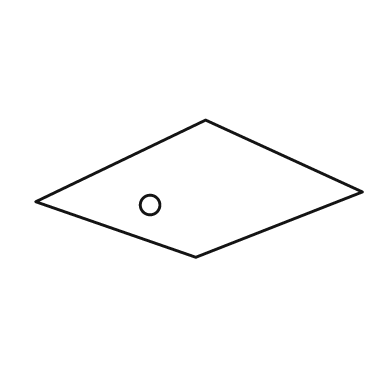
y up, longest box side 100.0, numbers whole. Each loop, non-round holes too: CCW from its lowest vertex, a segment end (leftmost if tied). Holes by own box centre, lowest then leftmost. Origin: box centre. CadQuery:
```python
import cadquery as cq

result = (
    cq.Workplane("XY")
    .moveTo(-1.0, -21.0)
    .lineTo(50.0, -1.0)
    .lineTo(2.0, 21.0)
    .lineTo(-50.0, -4.0)
    .close()
    .moveTo(-15.0, -5.0)
    .circle(3.0)
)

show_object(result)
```